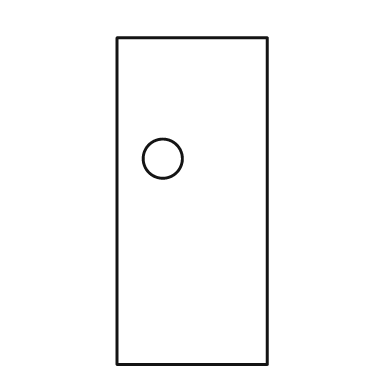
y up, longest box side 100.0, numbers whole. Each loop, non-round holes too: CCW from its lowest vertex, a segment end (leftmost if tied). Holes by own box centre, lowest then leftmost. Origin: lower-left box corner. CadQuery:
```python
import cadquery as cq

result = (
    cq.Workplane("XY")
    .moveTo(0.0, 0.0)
    .lineTo(46.0, 0.0)
    .lineTo(46.0, 100.0)
    .lineTo(0.0, 100.0)
    .close()
    .moveTo(14.0, 63.0)
    .circle(6.0)
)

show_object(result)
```